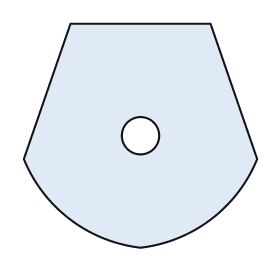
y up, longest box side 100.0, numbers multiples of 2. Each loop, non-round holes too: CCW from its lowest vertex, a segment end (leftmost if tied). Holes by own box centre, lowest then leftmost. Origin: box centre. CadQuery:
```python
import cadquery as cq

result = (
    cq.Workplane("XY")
    .moveTo(0.0, -48.0)
    .threePointArc((30.0, -36.0), (50.0, -10.0))
    .lineTo(30.0, 48.0)
    .lineTo(-30.0, 48.0)
    .lineTo(-50.0, -10.0)
    .threePointArc((-30.0, -36.0), (0.0, -48.0))
    .close()
    .moveTo(0.0, 0.0)
    .circle(8.0)
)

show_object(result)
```